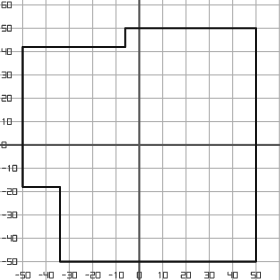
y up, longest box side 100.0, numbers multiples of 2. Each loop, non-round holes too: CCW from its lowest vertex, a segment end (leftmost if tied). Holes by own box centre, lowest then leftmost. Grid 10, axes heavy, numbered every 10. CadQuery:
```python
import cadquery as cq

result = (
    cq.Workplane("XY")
    .moveTo(-34.0, -50.0)
    .lineTo(50.0, -50.0)
    .lineTo(50.0, 50.0)
    .lineTo(-6.0, 50.0)
    .lineTo(-6.0, 42.0)
    .lineTo(-50.0, 42.0)
    .lineTo(-50.0, -18.0)
    .lineTo(-34.0, -18.0)
    .close()
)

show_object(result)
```